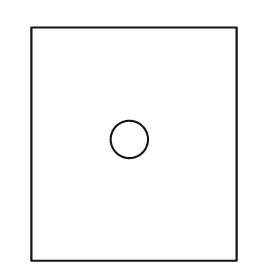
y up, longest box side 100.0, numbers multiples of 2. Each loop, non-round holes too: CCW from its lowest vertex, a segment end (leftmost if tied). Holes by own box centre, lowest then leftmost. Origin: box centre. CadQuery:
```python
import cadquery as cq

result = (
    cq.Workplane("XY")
    .moveTo(-44.0, -50.0)
    .lineTo(44.0, -50.0)
    .lineTo(44.0, 50.0)
    .lineTo(-44.0, 50.0)
    .close()
    .moveTo(-2.0, 2.0)
    .circle(8.0)
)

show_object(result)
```